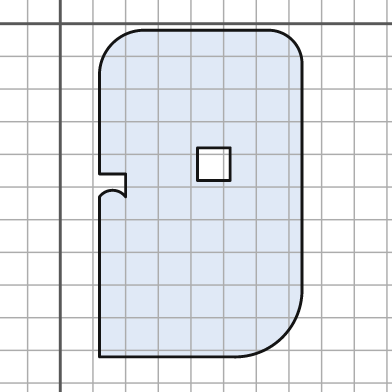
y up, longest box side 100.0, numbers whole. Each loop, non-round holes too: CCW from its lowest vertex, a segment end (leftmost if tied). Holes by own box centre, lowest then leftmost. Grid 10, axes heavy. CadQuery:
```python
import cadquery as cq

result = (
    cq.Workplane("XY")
    .moveTo(12.0, -102.0)
    .lineTo(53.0, -102.0)
    .threePointArc((68.0, -96.0), (74.0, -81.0))
    .lineTo(74.0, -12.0)
    .threePointArc((71.0, -5.0), (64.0, -2.0))
    .lineTo(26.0, -2.0)
    .threePointArc((16.0, -6.0), (12.0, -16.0))
    .lineTo(12.0, -46.0)
    .lineTo(20.0, -46.0)
    .lineTo(20.0, -53.0)
    .threePointArc((16.0, -51.0), (12.0, -53.0))
    .close()
    .moveTo(42.0, -48.0)
    .lineTo(52.0, -48.0)
    .lineTo(52.0, -38.0)
    .lineTo(42.0, -38.0)
    .close()
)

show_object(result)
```